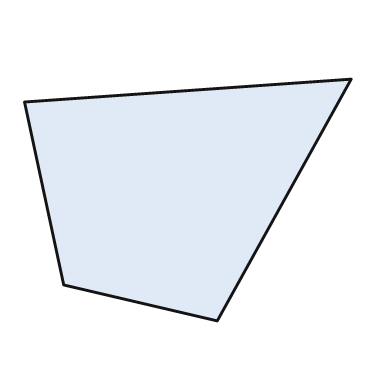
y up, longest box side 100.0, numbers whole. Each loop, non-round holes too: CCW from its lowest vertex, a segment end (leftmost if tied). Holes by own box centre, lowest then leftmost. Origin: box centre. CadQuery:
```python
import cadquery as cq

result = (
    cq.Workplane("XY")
    .moveTo(9.0, -37.0)
    .lineTo(50.0, 37.0)
    .lineTo(-50.0, 30.0)
    .lineTo(-38.0, -26.0)
    .close()
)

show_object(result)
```